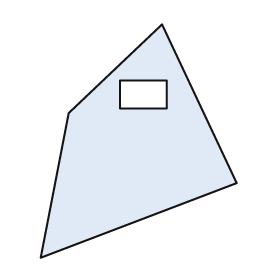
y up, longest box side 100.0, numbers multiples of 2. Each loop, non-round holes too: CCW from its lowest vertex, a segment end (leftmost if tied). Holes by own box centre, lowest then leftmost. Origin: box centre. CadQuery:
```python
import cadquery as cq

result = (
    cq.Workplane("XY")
    .moveTo(-42.0, -50.0)
    .lineTo(42.0, -18.0)
    .lineTo(10.0, 50.0)
    .lineTo(-30.0, 12.0)
    .close()
    .moveTo(-8.0, 14.0)
    .lineTo(12.0, 14.0)
    .lineTo(12.0, 26.0)
    .lineTo(-8.0, 26.0)
    .close()
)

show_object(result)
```